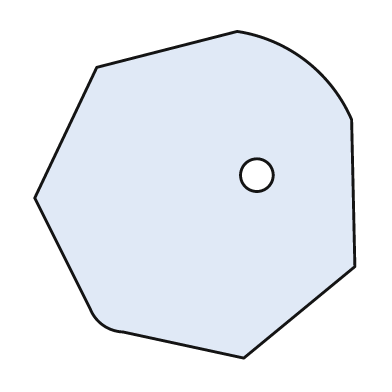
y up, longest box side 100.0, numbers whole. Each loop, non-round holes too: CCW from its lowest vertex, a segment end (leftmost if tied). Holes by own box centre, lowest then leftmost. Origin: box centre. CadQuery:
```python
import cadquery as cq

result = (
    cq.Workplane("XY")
    .moveTo(15.0, -50.0)
    .lineTo(49.0, -22.0)
    .lineTo(48.0, 23.0)
    .threePointArc((34.0, 41.0), (13.0, 50.0))
    .lineTo(-30.0, 39.0)
    .lineTo(-49.0, -1.0)
    .lineTo(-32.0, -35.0)
    .threePointArc((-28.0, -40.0), (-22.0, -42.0))
    .close()
    .moveTo(19.0, 6.0)
    .circle(5.0)
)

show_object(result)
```